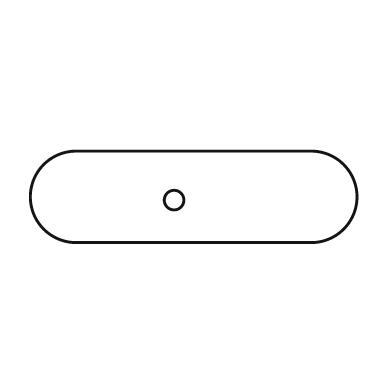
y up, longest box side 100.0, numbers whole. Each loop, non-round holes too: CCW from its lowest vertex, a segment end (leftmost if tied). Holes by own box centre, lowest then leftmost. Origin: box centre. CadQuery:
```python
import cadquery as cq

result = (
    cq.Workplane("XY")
    .moveTo(-36.0, -14.0)
    .lineTo(36.0, -14.0)
    .threePointArc((50.0, 0.0), (36.0, 14.0))
    .lineTo(-36.0, 14.0)
    .threePointArc((-50.0, 0.0), (-36.0, -14.0))
    .close()
    .moveTo(-6.0, -1.0)
    .circle(3.0)
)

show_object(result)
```